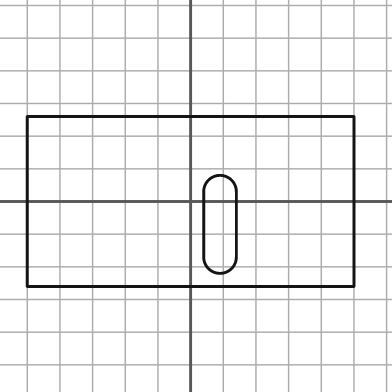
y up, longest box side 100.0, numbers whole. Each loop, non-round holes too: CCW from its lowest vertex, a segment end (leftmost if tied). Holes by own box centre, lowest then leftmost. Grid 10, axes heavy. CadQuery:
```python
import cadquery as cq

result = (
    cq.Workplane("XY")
    .moveTo(-50.0, -26.0)
    .lineTo(50.0, -26.0)
    .lineTo(50.0, 26.0)
    .lineTo(-50.0, 26.0)
    .close()
    .moveTo(4.0, -17.0)
    .threePointArc((9.0, -22.0), (14.0, -17.0))
    .lineTo(14.0, 3.0)
    .threePointArc((9.0, 8.0), (4.0, 3.0))
    .close()
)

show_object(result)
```